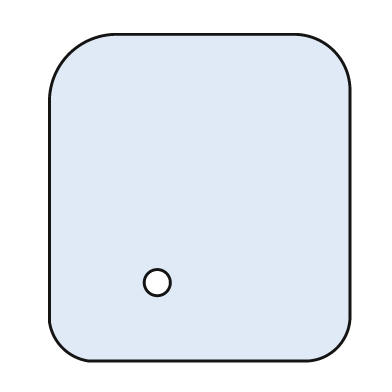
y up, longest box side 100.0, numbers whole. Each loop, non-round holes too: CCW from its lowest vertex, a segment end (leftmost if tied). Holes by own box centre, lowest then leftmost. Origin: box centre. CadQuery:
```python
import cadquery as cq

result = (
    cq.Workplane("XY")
    .moveTo(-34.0, -50.0)
    .lineTo(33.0, -50.0)
    .threePointArc((42.0, -46.0), (46.0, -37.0))
    .lineTo(46.0, 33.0)
    .threePointArc((41.0, 45.0), (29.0, 50.0))
    .lineTo(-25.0, 50.0)
    .threePointArc((-40.0, 44.0), (-46.0, 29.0))
    .lineTo(-46.0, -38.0)
    .threePointArc((-42.0, -46.0), (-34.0, -50.0))
    .close()
    .moveTo(-13.0, -26.0)
    .circle(4.0)
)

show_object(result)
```